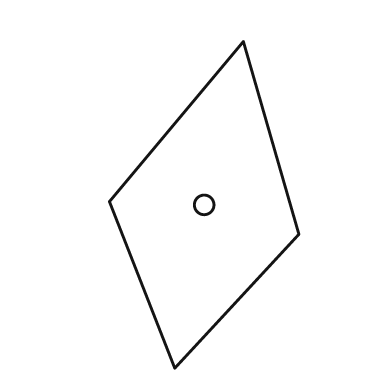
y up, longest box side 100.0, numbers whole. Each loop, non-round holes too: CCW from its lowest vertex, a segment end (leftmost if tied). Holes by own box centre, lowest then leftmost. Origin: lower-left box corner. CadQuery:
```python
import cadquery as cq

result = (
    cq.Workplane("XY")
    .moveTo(20.0, 0.0)
    .lineTo(58.0, 41.0)
    .lineTo(41.0, 100.0)
    .lineTo(0.0, 51.0)
    .close()
    .moveTo(29.0, 50.0)
    .circle(3.0)
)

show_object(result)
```